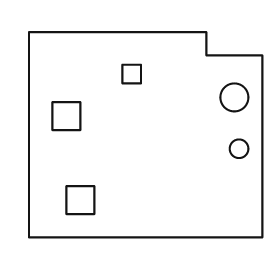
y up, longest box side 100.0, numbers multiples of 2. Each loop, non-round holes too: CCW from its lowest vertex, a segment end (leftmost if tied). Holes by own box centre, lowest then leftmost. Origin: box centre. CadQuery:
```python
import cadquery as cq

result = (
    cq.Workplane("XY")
    .moveTo(-50.0, -44.0)
    .lineTo(50.0, -44.0)
    .lineTo(50.0, 34.0)
    .lineTo(26.0, 34.0)
    .lineTo(26.0, 44.0)
    .lineTo(-50.0, 44.0)
    .close()
    .moveTo(-34.0, -34.0)
    .lineTo(-22.0, -34.0)
    .lineTo(-22.0, -22.0)
    .lineTo(-34.0, -22.0)
    .close()
    .moveTo(40.0, -6.0)
    .circle(4.0)
    .moveTo(-40.0, 2.0)
    .lineTo(-28.0, 2.0)
    .lineTo(-28.0, 14.0)
    .lineTo(-40.0, 14.0)
    .close()
    .moveTo(38.0, 16.0)
    .circle(6.0)
    .moveTo(-10.0, 22.0)
    .lineTo(-2.0, 22.0)
    .lineTo(-2.0, 30.0)
    .lineTo(-10.0, 30.0)
    .close()
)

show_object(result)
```